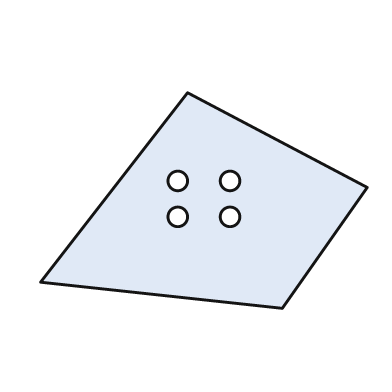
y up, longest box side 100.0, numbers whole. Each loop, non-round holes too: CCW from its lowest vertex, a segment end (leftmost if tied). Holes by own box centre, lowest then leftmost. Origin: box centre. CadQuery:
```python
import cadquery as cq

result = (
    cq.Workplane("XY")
    .moveTo(24.0, -33.0)
    .lineTo(50.0, 4.0)
    .lineTo(-5.0, 33.0)
    .lineTo(-50.0, -25.0)
    .close()
    .moveTo(-8.0, -5.0)
    .circle(3.0)
    .moveTo(8.0, -5.0)
    .circle(3.0)
    .moveTo(-8.0, 6.0)
    .circle(3.0)
    .moveTo(8.0, 6.0)
    .circle(3.0)
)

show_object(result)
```